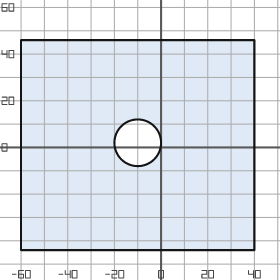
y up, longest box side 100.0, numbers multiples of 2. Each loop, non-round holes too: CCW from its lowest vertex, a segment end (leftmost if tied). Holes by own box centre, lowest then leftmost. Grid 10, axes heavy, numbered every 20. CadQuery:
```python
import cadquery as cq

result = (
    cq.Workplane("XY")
    .moveTo(-60.0, -44.0)
    .lineTo(40.0, -44.0)
    .lineTo(40.0, 46.0)
    .lineTo(-60.0, 46.0)
    .close()
    .moveTo(-10.0, 2.0)
    .circle(10.0)
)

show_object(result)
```